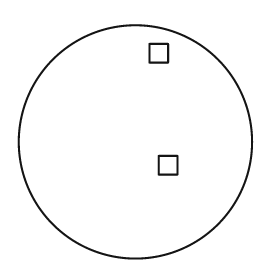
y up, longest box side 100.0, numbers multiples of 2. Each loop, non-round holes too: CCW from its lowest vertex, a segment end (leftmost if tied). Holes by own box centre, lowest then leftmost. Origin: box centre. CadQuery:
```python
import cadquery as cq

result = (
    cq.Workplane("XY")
    .moveTo(0.0, 0.0)
    .circle(50.0)
    .moveTo(10.0, -14.0)
    .lineTo(18.0, -14.0)
    .lineTo(18.0, -6.0)
    .lineTo(10.0, -6.0)
    .close()
    .moveTo(6.0, 34.0)
    .lineTo(14.0, 34.0)
    .lineTo(14.0, 42.0)
    .lineTo(6.0, 42.0)
    .close()
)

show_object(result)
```